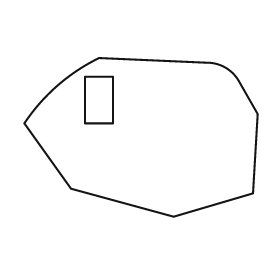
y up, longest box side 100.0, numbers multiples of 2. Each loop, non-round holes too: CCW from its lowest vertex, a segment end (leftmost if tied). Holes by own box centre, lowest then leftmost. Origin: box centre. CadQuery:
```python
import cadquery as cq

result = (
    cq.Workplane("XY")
    .moveTo(14.0, -34.0)
    .lineTo(48.0, -24.0)
    .lineTo(50.0, 10.0)
    .lineTo(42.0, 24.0)
    .threePointArc((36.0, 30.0), (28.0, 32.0))
    .lineTo(-18.0, 34.0)
    .threePointArc((-36.0, 22.0), (-50.0, 6.0))
    .lineTo(-30.0, -22.0)
    .close()
    .moveTo(-24.0, 6.0)
    .lineTo(-12.0, 6.0)
    .lineTo(-12.0, 26.0)
    .lineTo(-24.0, 26.0)
    .close()
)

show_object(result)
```